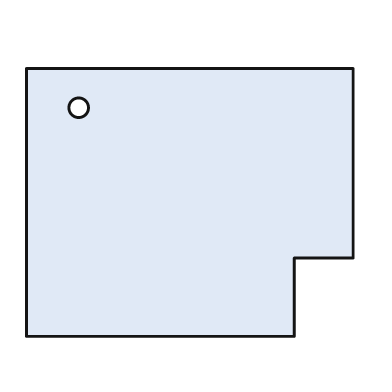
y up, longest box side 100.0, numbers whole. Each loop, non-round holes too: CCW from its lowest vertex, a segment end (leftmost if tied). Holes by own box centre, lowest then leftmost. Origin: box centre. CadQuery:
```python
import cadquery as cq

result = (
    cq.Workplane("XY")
    .moveTo(-50.0, -41.0)
    .lineTo(32.0, -41.0)
    .lineTo(32.0, -17.0)
    .lineTo(50.0, -17.0)
    .lineTo(50.0, 41.0)
    .lineTo(-50.0, 41.0)
    .close()
    .moveTo(-34.0, 29.0)
    .circle(3.0)
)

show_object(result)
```